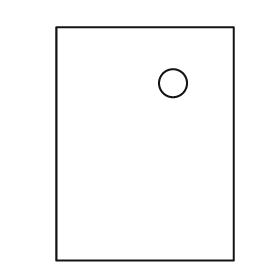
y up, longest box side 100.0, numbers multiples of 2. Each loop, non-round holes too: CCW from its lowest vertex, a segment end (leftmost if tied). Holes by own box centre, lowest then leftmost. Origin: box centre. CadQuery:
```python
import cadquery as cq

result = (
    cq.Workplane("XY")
    .moveTo(-38.0, -50.0)
    .lineTo(38.0, -50.0)
    .lineTo(38.0, 50.0)
    .lineTo(-38.0, 50.0)
    .close()
    .moveTo(12.0, 26.0)
    .circle(6.0)
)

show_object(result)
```